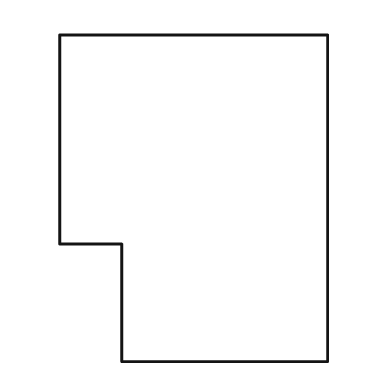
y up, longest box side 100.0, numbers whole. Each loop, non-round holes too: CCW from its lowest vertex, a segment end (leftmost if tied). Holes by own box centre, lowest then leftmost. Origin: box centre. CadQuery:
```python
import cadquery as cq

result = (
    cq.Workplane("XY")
    .moveTo(-22.0, -50.0)
    .lineTo(41.0, -50.0)
    .lineTo(41.0, 50.0)
    .lineTo(-41.0, 50.0)
    .lineTo(-41.0, -14.0)
    .lineTo(-22.0, -14.0)
    .close()
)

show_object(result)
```